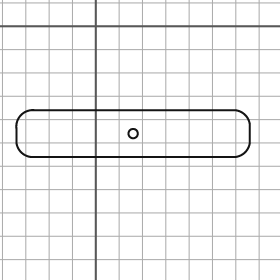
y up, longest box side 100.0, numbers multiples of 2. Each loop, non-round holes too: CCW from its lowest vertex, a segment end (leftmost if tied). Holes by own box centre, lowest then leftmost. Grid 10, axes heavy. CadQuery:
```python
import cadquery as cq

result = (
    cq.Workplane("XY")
    .moveTo(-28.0, -56.0)
    .lineTo(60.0, -56.0)
    .threePointArc((64.0, -54.0), (66.0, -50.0))
    .lineTo(66.0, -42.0)
    .threePointArc((64.0, -38.0), (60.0, -36.0))
    .lineTo(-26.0, -36.0)
    .threePointArc((-32.0, -38.0), (-34.0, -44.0))
    .lineTo(-34.0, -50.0)
    .threePointArc((-32.0, -54.0), (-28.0, -56.0))
    .close()
    .moveTo(16.0, -46.0)
    .circle(2.0)
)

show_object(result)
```